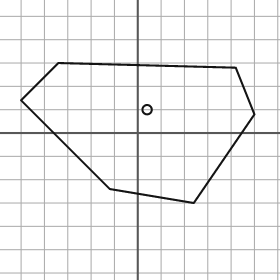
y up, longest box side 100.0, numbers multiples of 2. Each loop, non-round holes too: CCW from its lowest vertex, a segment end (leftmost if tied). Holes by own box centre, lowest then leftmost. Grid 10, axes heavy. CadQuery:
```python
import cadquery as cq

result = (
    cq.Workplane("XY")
    .moveTo(24.0, -30.0)
    .lineTo(50.0, 8.0)
    .lineTo(42.0, 28.0)
    .lineTo(-34.0, 30.0)
    .lineTo(-50.0, 14.0)
    .lineTo(-12.0, -24.0)
    .close()
    .moveTo(4.0, 10.0)
    .circle(2.0)
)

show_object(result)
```